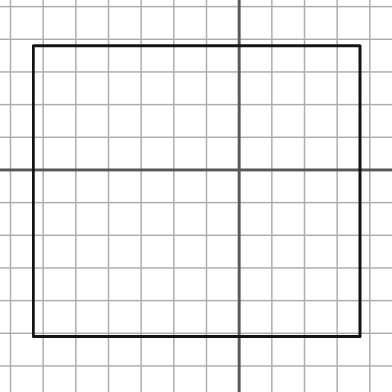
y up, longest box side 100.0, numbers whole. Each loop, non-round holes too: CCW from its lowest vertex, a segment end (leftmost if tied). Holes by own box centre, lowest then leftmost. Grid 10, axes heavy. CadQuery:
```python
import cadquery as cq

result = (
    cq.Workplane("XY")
    .moveTo(-63.0, -51.0)
    .lineTo(37.0, -51.0)
    .lineTo(37.0, 38.0)
    .lineTo(-63.0, 38.0)
    .close()
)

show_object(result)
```